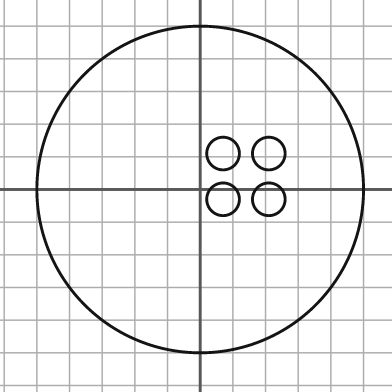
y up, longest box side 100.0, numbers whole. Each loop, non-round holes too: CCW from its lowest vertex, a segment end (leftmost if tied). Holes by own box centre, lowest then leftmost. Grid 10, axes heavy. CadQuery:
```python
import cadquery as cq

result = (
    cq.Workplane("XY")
    .moveTo(0.0, 0.0)
    .circle(50.0)
    .moveTo(7.0, -3.0)
    .circle(5.0)
    .moveTo(21.0, -3.0)
    .circle(5.0)
    .moveTo(7.0, 11.0)
    .circle(5.0)
    .moveTo(21.0, 11.0)
    .circle(5.0)
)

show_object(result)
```